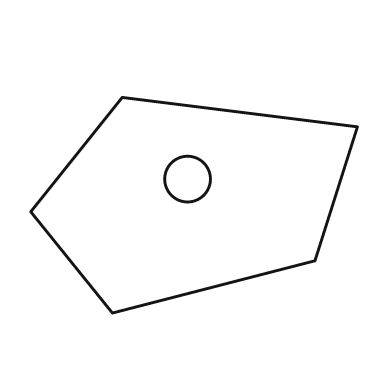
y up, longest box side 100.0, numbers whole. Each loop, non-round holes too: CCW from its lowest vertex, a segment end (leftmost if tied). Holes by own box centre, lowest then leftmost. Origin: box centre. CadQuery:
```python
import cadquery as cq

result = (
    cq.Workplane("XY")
    .moveTo(-25.0, -33.0)
    .lineTo(37.0, -17.0)
    .lineTo(50.0, 24.0)
    .lineTo(-22.0, 33.0)
    .lineTo(-50.0, -2.0)
    .close()
    .moveTo(-2.0, 8.0)
    .circle(7.0)
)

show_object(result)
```